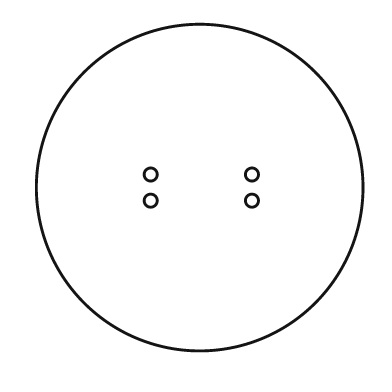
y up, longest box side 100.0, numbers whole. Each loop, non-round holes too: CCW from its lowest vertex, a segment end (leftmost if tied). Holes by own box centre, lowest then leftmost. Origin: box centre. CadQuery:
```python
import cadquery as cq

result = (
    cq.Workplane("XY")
    .moveTo(0.0, 0.0)
    .circle(50.0)
    .moveTo(-15.0, -4.0)
    .circle(2.0)
    .moveTo(16.0, -4.0)
    .circle(2.0)
    .moveTo(-15.0, 4.0)
    .circle(2.0)
    .moveTo(16.0, 4.0)
    .circle(2.0)
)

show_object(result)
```